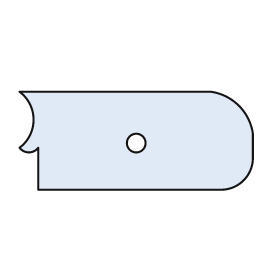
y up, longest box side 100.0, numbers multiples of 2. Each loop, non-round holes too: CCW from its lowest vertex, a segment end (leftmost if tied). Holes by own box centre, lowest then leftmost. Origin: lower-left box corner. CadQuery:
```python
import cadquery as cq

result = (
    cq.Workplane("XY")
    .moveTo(8.0, 0.0)
    .lineTo(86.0, 0.0)
    .threePointArc((96.0, 4.0), (100.0, 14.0))
    .lineTo(100.0, 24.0)
    .threePointArc((94.0, 36.0), (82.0, 42.0))
    .lineTo(0.0, 42.0)
    .threePointArc((6.0, 30.0), (0.0, 18.0))
    .threePointArc((4.0, 16.0), (8.0, 18.0))
    .close()
    .moveTo(50.0, 20.0)
    .circle(4.0)
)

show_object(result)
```